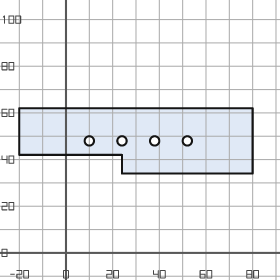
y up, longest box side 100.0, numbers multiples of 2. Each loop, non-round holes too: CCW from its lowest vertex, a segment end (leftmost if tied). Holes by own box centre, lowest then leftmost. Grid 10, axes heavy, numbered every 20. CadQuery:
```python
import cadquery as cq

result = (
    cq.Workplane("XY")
    .moveTo(24.0, 34.0)
    .lineTo(80.0, 34.0)
    .lineTo(80.0, 62.0)
    .lineTo(-20.0, 62.0)
    .lineTo(-20.0, 42.0)
    .lineTo(24.0, 42.0)
    .close()
    .moveTo(10.0, 48.0)
    .circle(2.0)
    .moveTo(24.0, 48.0)
    .circle(2.0)
    .moveTo(38.0, 48.0)
    .circle(2.0)
    .moveTo(52.0, 48.0)
    .circle(2.0)
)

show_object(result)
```